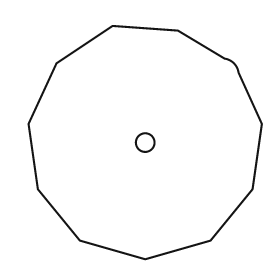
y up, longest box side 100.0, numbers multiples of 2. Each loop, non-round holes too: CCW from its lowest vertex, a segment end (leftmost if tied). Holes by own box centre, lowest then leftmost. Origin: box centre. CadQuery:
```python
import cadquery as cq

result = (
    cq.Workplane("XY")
    .moveTo(0.0, -50.0)
    .lineTo(28.0, -42.0)
    .lineTo(46.0, -20.0)
    .lineTo(50.0, 8.0)
    .lineTo(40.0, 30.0)
    .threePointArc((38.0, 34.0), (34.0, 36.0))
    .lineTo(14.0, 48.0)
    .lineTo(-14.0, 50.0)
    .lineTo(-38.0, 34.0)
    .lineTo(-50.0, 8.0)
    .lineTo(-46.0, -20.0)
    .lineTo(-28.0, -42.0)
    .close()
    .moveTo(0.0, 0.0)
    .circle(4.0)
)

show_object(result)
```